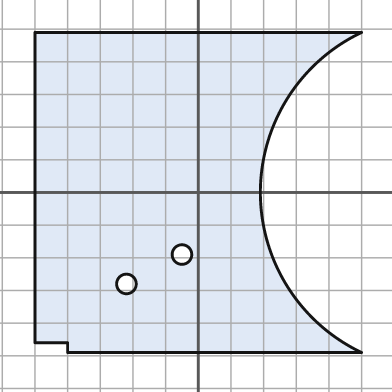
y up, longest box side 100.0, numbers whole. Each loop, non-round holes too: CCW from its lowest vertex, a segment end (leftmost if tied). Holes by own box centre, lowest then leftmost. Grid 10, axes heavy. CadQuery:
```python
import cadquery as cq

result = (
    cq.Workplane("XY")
    .moveTo(-40.0, -49.0)
    .lineTo(50.0, -49.0)
    .threePointArc((19.0, 0.0), (50.0, 49.0))
    .lineTo(-50.0, 49.0)
    .lineTo(-50.0, -46.0)
    .lineTo(-40.0, -46.0)
    .close()
    .moveTo(-22.0, -28.0)
    .circle(3.0)
    .moveTo(-5.0, -19.0)
    .circle(3.0)
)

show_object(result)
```